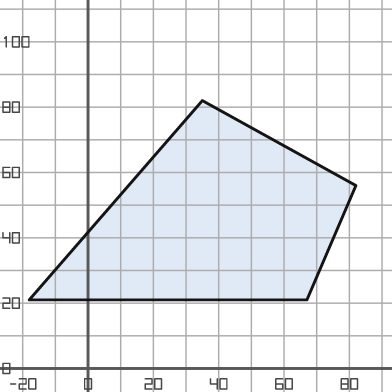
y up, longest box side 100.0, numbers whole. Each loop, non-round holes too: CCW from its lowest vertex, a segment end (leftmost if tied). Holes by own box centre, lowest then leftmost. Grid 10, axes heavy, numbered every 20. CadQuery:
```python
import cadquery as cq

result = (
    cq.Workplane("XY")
    .moveTo(-18.0, 21.0)
    .lineTo(67.0, 21.0)
    .lineTo(82.0, 56.0)
    .lineTo(35.0, 82.0)
    .close()
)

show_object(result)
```